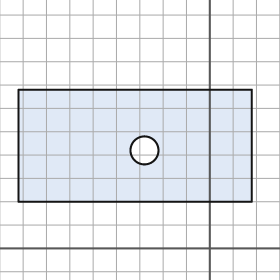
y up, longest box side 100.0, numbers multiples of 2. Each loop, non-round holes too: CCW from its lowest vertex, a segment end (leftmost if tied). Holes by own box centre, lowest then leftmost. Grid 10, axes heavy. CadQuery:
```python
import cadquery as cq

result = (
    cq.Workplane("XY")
    .moveTo(-82.0, 20.0)
    .lineTo(18.0, 20.0)
    .lineTo(18.0, 68.0)
    .lineTo(-82.0, 68.0)
    .close()
    .moveTo(-28.0, 42.0)
    .circle(6.0)
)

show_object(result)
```